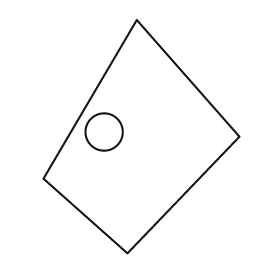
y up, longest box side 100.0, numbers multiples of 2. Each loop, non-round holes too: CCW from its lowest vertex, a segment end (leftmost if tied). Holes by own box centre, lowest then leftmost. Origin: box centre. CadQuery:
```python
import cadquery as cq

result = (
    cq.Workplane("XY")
    .moveTo(-6.0, -50.0)
    .lineTo(42.0, 0.0)
    .lineTo(-2.0, 50.0)
    .lineTo(-42.0, -18.0)
    .close()
    .moveTo(-16.0, 2.0)
    .circle(8.0)
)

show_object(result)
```